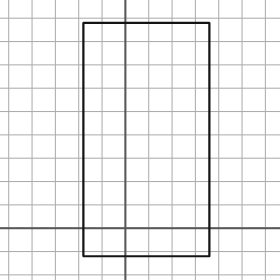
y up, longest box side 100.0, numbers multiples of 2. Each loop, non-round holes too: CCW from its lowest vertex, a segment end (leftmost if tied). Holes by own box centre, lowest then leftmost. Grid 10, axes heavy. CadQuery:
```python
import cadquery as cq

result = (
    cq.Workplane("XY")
    .moveTo(-18.0, -12.0)
    .lineTo(36.0, -12.0)
    .lineTo(36.0, 88.0)
    .lineTo(-18.0, 88.0)
    .close()
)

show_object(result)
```